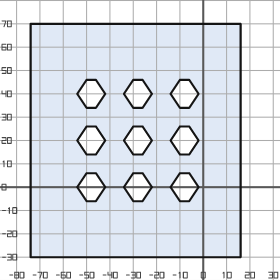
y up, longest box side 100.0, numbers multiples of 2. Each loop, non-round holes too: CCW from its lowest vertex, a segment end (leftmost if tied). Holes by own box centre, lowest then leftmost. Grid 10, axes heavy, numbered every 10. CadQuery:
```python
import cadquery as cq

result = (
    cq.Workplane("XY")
    .moveTo(-74.0, -30.0)
    .lineTo(16.0, -30.0)
    .lineTo(16.0, 70.0)
    .lineTo(-74.0, 70.0)
    .close()
    .moveTo(-50.0, -6.0)
    .lineTo(-46.0, -6.0)
    .lineTo(-42.0, 0.0)
    .lineTo(-46.0, 6.0)
    .lineTo(-50.0, 6.0)
    .lineTo(-54.0, 0.0)
    .close()
    .moveTo(-30.0, -6.0)
    .lineTo(-26.0, -6.0)
    .lineTo(-22.0, 0.0)
    .lineTo(-26.0, 6.0)
    .lineTo(-30.0, 6.0)
    .lineTo(-34.0, 0.0)
    .close()
    .moveTo(-10.0, -6.0)
    .lineTo(-6.0, -6.0)
    .lineTo(-2.0, 0.0)
    .lineTo(-6.0, 6.0)
    .lineTo(-10.0, 6.0)
    .lineTo(-14.0, 0.0)
    .close()
    .moveTo(-50.0, 14.0)
    .lineTo(-46.0, 14.0)
    .lineTo(-42.0, 20.0)
    .lineTo(-46.0, 26.0)
    .lineTo(-50.0, 26.0)
    .lineTo(-54.0, 20.0)
    .close()
    .moveTo(-30.0, 14.0)
    .lineTo(-26.0, 14.0)
    .lineTo(-22.0, 20.0)
    .lineTo(-26.0, 26.0)
    .lineTo(-30.0, 26.0)
    .lineTo(-34.0, 20.0)
    .close()
    .moveTo(-10.0, 14.0)
    .lineTo(-6.0, 14.0)
    .lineTo(-2.0, 20.0)
    .lineTo(-6.0, 26.0)
    .lineTo(-10.0, 26.0)
    .lineTo(-14.0, 20.0)
    .close()
    .moveTo(-50.0, 34.0)
    .lineTo(-46.0, 34.0)
    .lineTo(-42.0, 40.0)
    .lineTo(-46.0, 46.0)
    .lineTo(-50.0, 46.0)
    .lineTo(-54.0, 40.0)
    .close()
    .moveTo(-30.0, 34.0)
    .lineTo(-26.0, 34.0)
    .lineTo(-22.0, 40.0)
    .lineTo(-26.0, 46.0)
    .lineTo(-30.0, 46.0)
    .lineTo(-34.0, 40.0)
    .close()
    .moveTo(-10.0, 34.0)
    .lineTo(-6.0, 34.0)
    .lineTo(-2.0, 40.0)
    .lineTo(-6.0, 46.0)
    .lineTo(-10.0, 46.0)
    .lineTo(-14.0, 40.0)
    .close()
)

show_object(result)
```